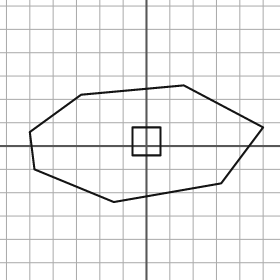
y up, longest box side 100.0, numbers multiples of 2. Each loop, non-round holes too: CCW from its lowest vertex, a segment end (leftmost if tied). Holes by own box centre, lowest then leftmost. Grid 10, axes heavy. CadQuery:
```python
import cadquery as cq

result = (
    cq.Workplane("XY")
    .moveTo(-14.0, -24.0)
    .lineTo(32.0, -16.0)
    .lineTo(50.0, 8.0)
    .lineTo(16.0, 26.0)
    .lineTo(-28.0, 22.0)
    .lineTo(-50.0, 6.0)
    .lineTo(-48.0, -10.0)
    .close()
    .moveTo(-6.0, -4.0)
    .lineTo(6.0, -4.0)
    .lineTo(6.0, 8.0)
    .lineTo(-6.0, 8.0)
    .close()
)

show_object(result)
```